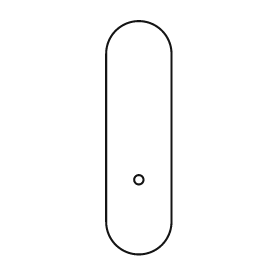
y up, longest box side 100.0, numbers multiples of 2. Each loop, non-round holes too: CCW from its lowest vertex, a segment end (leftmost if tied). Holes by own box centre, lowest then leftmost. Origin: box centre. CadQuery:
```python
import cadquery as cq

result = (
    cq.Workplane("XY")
    .moveTo(-14.0, -36.0)
    .threePointArc((0.0, -50.0), (14.0, -36.0))
    .lineTo(14.0, 36.0)
    .threePointArc((0.0, 50.0), (-14.0, 36.0))
    .close()
    .moveTo(0.0, -18.0)
    .circle(2.0)
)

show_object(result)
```